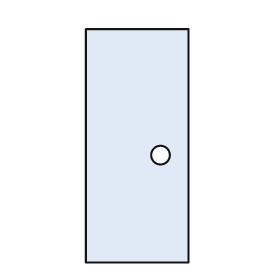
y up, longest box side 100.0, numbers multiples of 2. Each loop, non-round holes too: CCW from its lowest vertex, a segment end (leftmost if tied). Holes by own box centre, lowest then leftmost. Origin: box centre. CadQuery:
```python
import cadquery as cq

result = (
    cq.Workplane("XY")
    .moveTo(-22.0, -50.0)
    .lineTo(22.0, -50.0)
    .lineTo(22.0, 50.0)
    .lineTo(-22.0, 50.0)
    .close()
    .moveTo(10.0, -4.0)
    .circle(4.0)
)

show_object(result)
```